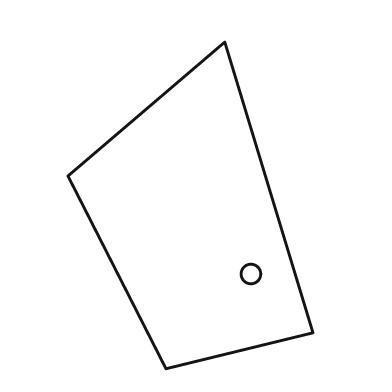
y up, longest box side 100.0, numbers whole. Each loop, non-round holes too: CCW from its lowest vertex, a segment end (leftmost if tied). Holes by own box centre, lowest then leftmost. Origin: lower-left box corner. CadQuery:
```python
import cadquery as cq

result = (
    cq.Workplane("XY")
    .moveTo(30.0, 0.0)
    .lineTo(75.0, 11.0)
    .lineTo(48.0, 100.0)
    .lineTo(0.0, 59.0)
    .close()
    .moveTo(56.0, 29.0)
    .circle(3.0)
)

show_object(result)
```